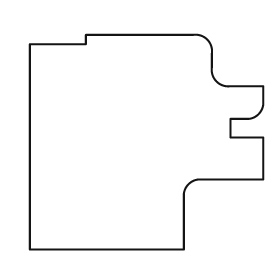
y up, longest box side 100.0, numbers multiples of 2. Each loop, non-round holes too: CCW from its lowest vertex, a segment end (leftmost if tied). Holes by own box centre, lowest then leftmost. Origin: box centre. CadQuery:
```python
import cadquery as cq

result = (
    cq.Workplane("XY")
    .moveTo(-50.0, -46.0)
    .lineTo(16.0, -46.0)
    .lineTo(16.0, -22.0)
    .threePointArc((18.0, -18.0), (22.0, -16.0))
    .lineTo(50.0, -16.0)
    .lineTo(50.0, 2.0)
    .lineTo(36.0, 2.0)
    .lineTo(36.0, 10.0)
    .lineTo(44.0, 10.0)
    .threePointArc((48.0, 12.0), (50.0, 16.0))
    .lineTo(50.0, 24.0)
    .lineTo(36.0, 24.0)
    .threePointArc((30.0, 26.0), (28.0, 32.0))
    .lineTo(28.0, 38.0)
    .threePointArc((26.0, 44.0), (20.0, 46.0))
    .lineTo(-26.0, 46.0)
    .lineTo(-26.0, 42.0)
    .lineTo(-50.0, 42.0)
    .close()
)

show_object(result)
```